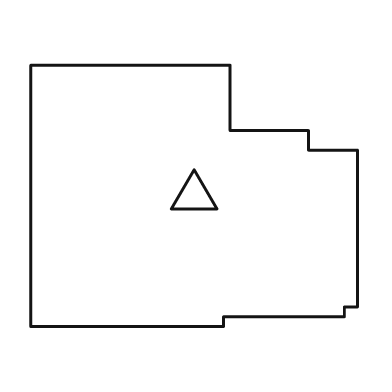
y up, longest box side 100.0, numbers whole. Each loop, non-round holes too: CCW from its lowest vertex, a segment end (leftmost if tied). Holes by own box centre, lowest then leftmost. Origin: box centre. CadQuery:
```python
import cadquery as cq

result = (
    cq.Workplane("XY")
    .moveTo(-50.0, -40.0)
    .lineTo(9.0, -40.0)
    .lineTo(9.0, -37.0)
    .lineTo(46.0, -37.0)
    .lineTo(46.0, -34.0)
    .lineTo(50.0, -34.0)
    .lineTo(50.0, 14.0)
    .lineTo(35.0, 14.0)
    .lineTo(35.0, 20.0)
    .lineTo(11.0, 20.0)
    .lineTo(11.0, 40.0)
    .lineTo(-50.0, 40.0)
    .close()
    .moveTo(-7.0, -4.0)
    .lineTo(7.0, -4.0)
    .lineTo(0.0, 8.0)
    .close()
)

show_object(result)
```